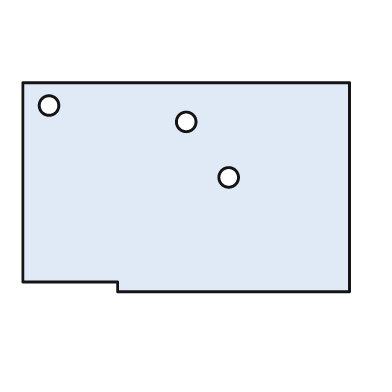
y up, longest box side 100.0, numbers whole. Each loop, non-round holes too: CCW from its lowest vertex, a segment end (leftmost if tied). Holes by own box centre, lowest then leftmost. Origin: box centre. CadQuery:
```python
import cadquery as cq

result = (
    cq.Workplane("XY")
    .moveTo(-21.0, -32.0)
    .lineTo(50.0, -32.0)
    .lineTo(50.0, 32.0)
    .lineTo(-50.0, 32.0)
    .lineTo(-50.0, -29.0)
    .lineTo(-21.0, -29.0)
    .close()
    .moveTo(13.0, 3.0)
    .circle(3.0)
    .moveTo(0.0, 20.0)
    .circle(3.0)
    .moveTo(-42.0, 25.0)
    .circle(3.0)
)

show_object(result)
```